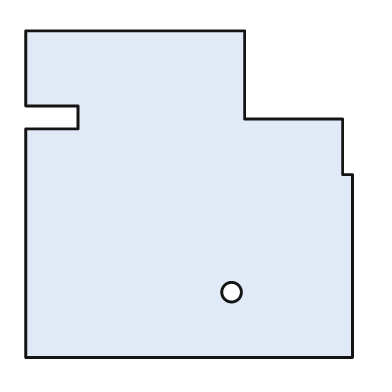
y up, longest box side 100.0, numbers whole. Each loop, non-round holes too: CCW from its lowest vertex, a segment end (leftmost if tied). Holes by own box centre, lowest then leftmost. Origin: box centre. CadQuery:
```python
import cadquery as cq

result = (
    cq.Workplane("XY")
    .moveTo(-50.0, -50.0)
    .lineTo(50.0, -50.0)
    .lineTo(50.0, 6.0)
    .lineTo(47.0, 6.0)
    .lineTo(47.0, 23.0)
    .lineTo(17.0, 23.0)
    .lineTo(17.0, 50.0)
    .lineTo(-50.0, 50.0)
    .lineTo(-50.0, 27.0)
    .lineTo(-34.0, 27.0)
    .lineTo(-34.0, 20.0)
    .lineTo(-50.0, 20.0)
    .close()
    .moveTo(13.0, -30.0)
    .circle(3.0)
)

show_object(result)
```